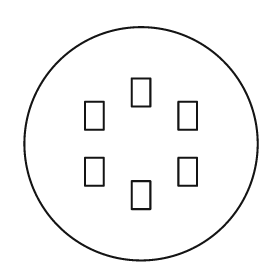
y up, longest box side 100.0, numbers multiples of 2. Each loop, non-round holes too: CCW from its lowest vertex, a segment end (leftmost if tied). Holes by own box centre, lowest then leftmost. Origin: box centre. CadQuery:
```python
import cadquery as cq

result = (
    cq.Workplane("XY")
    .moveTo(0.0, 0.0)
    .circle(50.0)
    .moveTo(-4.0, -28.0)
    .lineTo(4.0, -28.0)
    .lineTo(4.0, -16.0)
    .lineTo(-4.0, -16.0)
    .close()
    .moveTo(-24.0, -18.0)
    .lineTo(-16.0, -18.0)
    .lineTo(-16.0, -6.0)
    .lineTo(-24.0, -6.0)
    .close()
    .moveTo(16.0, -18.0)
    .lineTo(24.0, -18.0)
    .lineTo(24.0, -6.0)
    .lineTo(16.0, -6.0)
    .close()
    .moveTo(-24.0, 6.0)
    .lineTo(-16.0, 6.0)
    .lineTo(-16.0, 18.0)
    .lineTo(-24.0, 18.0)
    .close()
    .moveTo(16.0, 6.0)
    .lineTo(24.0, 6.0)
    .lineTo(24.0, 18.0)
    .lineTo(16.0, 18.0)
    .close()
    .moveTo(-4.0, 16.0)
    .lineTo(4.0, 16.0)
    .lineTo(4.0, 28.0)
    .lineTo(-4.0, 28.0)
    .close()
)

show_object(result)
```